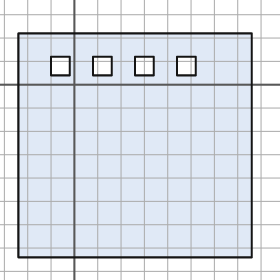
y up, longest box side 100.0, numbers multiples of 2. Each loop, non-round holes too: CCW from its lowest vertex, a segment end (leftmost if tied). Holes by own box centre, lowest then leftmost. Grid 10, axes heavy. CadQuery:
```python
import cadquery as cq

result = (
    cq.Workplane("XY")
    .moveTo(-24.0, -74.0)
    .lineTo(76.0, -74.0)
    .lineTo(76.0, 22.0)
    .lineTo(-24.0, 22.0)
    .close()
    .moveTo(-10.0, 4.0)
    .lineTo(-2.0, 4.0)
    .lineTo(-2.0, 12.0)
    .lineTo(-10.0, 12.0)
    .close()
    .moveTo(8.0, 4.0)
    .lineTo(16.0, 4.0)
    .lineTo(16.0, 12.0)
    .lineTo(8.0, 12.0)
    .close()
    .moveTo(26.0, 4.0)
    .lineTo(34.0, 4.0)
    .lineTo(34.0, 12.0)
    .lineTo(26.0, 12.0)
    .close()
    .moveTo(44.0, 4.0)
    .lineTo(52.0, 4.0)
    .lineTo(52.0, 12.0)
    .lineTo(44.0, 12.0)
    .close()
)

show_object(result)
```